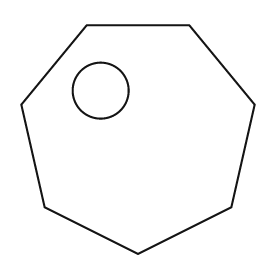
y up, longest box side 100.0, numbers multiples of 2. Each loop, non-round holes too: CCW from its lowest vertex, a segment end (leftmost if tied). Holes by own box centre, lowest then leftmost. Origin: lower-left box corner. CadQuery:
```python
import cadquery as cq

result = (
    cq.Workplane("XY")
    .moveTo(50.0, 0.0)
    .lineTo(90.0, 20.0)
    .lineTo(100.0, 64.0)
    .lineTo(72.0, 98.0)
    .lineTo(28.0, 98.0)
    .lineTo(0.0, 64.0)
    .lineTo(10.0, 20.0)
    .close()
    .moveTo(34.0, 70.0)
    .circle(12.0)
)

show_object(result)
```